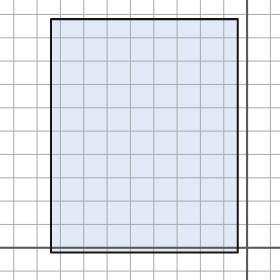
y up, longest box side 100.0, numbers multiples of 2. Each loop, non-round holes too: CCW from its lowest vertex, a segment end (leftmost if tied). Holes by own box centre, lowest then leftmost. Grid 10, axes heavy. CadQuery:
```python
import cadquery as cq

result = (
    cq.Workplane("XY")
    .moveTo(-84.0, -2.0)
    .lineTo(-4.0, -2.0)
    .lineTo(-4.0, 98.0)
    .lineTo(-84.0, 98.0)
    .close()
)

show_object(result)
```